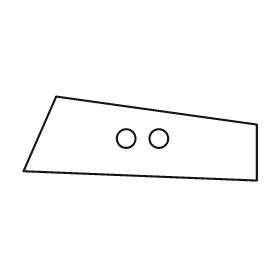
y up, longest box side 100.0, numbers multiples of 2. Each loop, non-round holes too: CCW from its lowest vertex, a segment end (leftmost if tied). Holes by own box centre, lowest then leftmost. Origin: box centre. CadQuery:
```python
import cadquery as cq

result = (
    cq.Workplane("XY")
    .moveTo(50.0, -18.0)
    .lineTo(50.0, 6.0)
    .lineTo(-36.0, 18.0)
    .lineTo(-50.0, -14.0)
    .close()
    .moveTo(-6.0, 0.0)
    .circle(4.0)
    .moveTo(8.0, 0.0)
    .circle(4.0)
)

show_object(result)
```